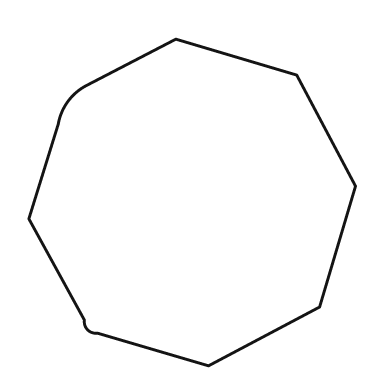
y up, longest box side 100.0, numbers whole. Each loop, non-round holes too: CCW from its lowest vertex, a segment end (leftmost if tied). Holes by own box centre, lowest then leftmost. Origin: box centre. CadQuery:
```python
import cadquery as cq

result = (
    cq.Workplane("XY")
    .moveTo(5.0, -50.0)
    .lineTo(39.0, -32.0)
    .lineTo(50.0, 5.0)
    .lineTo(32.0, 39.0)
    .lineTo(-5.0, 50.0)
    .lineTo(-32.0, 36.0)
    .threePointArc((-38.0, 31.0), (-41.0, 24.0))
    .lineTo(-50.0, -5.0)
    .lineTo(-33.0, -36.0)
    .threePointArc((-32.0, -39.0), (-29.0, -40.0))
    .close()
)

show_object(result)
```